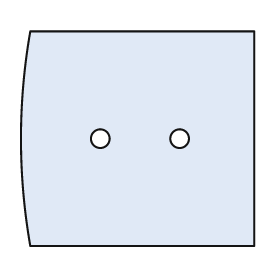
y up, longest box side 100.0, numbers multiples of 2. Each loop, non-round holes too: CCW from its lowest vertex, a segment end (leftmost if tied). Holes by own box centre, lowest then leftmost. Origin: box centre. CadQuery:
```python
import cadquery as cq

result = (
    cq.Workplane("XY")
    .moveTo(-46.0, -46.0)
    .lineTo(50.0, -46.0)
    .lineTo(50.0, 46.0)
    .lineTo(-46.0, 46.0)
    .threePointArc((-50.0, 0.0), (-46.0, -46.0))
    .close()
    .moveTo(-16.0, 0.0)
    .circle(4.0)
    .moveTo(18.0, 0.0)
    .circle(4.0)
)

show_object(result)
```